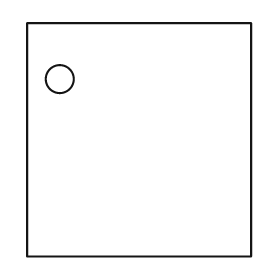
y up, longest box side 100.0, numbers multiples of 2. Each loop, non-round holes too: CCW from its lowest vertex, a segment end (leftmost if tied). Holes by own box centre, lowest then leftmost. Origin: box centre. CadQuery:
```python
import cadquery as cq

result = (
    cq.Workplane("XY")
    .moveTo(-48.0, -50.0)
    .lineTo(48.0, -50.0)
    .lineTo(48.0, 50.0)
    .lineTo(-48.0, 50.0)
    .close()
    .moveTo(-34.0, 26.0)
    .circle(6.0)
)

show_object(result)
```